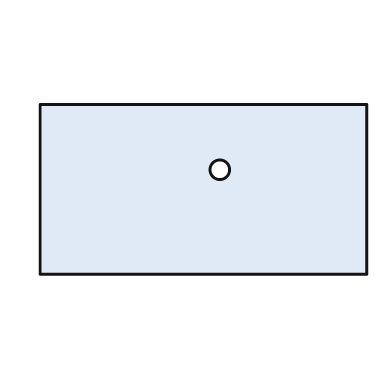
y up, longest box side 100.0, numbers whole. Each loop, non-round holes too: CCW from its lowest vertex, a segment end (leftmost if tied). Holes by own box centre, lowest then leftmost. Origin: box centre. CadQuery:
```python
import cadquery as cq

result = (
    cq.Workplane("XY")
    .moveTo(-50.0, -26.0)
    .lineTo(50.0, -26.0)
    .lineTo(50.0, 26.0)
    .lineTo(-50.0, 26.0)
    .close()
    .moveTo(5.0, 6.0)
    .circle(3.0)
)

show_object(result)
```